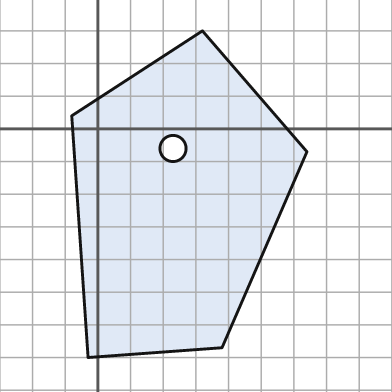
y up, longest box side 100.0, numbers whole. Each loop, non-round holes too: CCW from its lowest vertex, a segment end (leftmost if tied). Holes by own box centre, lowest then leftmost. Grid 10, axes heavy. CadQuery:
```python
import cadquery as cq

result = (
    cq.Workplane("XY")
    .moveTo(-3.0, -70.0)
    .lineTo(38.0, -67.0)
    .lineTo(64.0, -7.0)
    .lineTo(32.0, 30.0)
    .lineTo(-8.0, 4.0)
    .close()
    .moveTo(23.0, -6.0)
    .circle(4.0)
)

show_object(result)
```